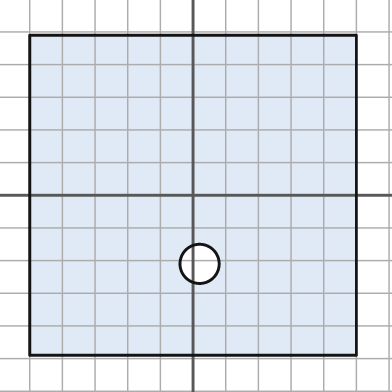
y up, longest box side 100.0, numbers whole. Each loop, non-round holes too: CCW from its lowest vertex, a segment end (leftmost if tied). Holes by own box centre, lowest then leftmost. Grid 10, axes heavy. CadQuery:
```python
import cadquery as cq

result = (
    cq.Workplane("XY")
    .moveTo(-50.0, -49.0)
    .lineTo(50.0, -49.0)
    .lineTo(50.0, 49.0)
    .lineTo(-50.0, 49.0)
    .close()
    .moveTo(2.0, -21.0)
    .circle(6.0)
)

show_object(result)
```